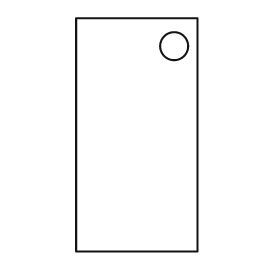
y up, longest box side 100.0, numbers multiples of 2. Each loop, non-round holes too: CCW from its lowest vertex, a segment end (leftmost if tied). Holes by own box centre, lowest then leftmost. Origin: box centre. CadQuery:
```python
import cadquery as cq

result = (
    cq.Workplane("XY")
    .moveTo(-26.0, -50.0)
    .lineTo(26.0, -50.0)
    .lineTo(26.0, 50.0)
    .lineTo(-26.0, 50.0)
    .close()
    .moveTo(16.0, 38.0)
    .circle(6.0)
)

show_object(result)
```